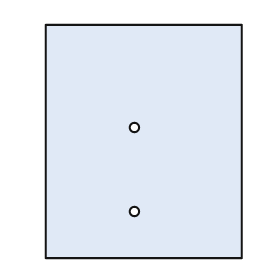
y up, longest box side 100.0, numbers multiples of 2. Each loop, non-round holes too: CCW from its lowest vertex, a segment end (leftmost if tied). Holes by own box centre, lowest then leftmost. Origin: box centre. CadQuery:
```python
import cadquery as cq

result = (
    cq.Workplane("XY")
    .moveTo(-42.0, -50.0)
    .lineTo(42.0, -50.0)
    .lineTo(42.0, 50.0)
    .lineTo(-42.0, 50.0)
    .close()
    .moveTo(-4.0, -30.0)
    .circle(2.0)
    .moveTo(-4.0, 6.0)
    .circle(2.0)
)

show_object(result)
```